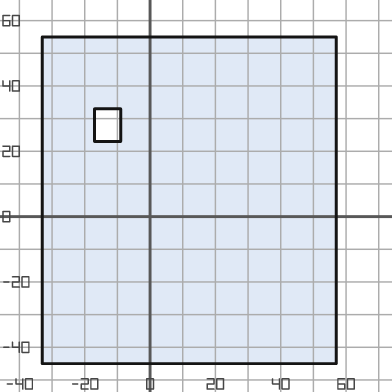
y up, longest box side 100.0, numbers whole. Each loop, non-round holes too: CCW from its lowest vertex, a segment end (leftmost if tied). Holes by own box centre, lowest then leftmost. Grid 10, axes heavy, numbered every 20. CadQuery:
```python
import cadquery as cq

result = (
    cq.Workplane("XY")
    .moveTo(-33.0, -45.0)
    .lineTo(57.0, -45.0)
    .lineTo(57.0, 55.0)
    .lineTo(-33.0, 55.0)
    .close()
    .moveTo(-17.0, 23.0)
    .lineTo(-9.0, 23.0)
    .lineTo(-9.0, 33.0)
    .lineTo(-17.0, 33.0)
    .close()
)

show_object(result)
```